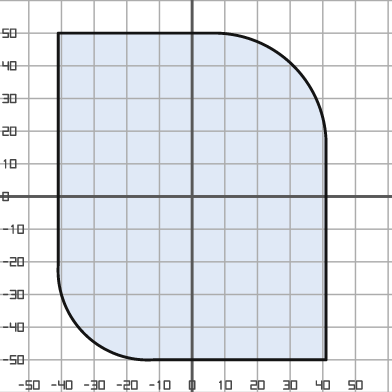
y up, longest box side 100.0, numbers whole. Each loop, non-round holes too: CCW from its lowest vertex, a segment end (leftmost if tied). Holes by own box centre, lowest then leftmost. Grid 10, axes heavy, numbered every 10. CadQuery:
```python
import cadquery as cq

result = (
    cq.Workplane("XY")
    .moveTo(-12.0, -50.0)
    .lineTo(41.0, -50.0)
    .lineTo(41.0, 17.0)
    .threePointArc((31.0, 40.0), (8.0, 50.0))
    .lineTo(-41.0, 50.0)
    .lineTo(-41.0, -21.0)
    .threePointArc((-33.0, -42.0), (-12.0, -50.0))
    .close()
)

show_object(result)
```